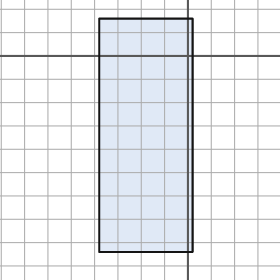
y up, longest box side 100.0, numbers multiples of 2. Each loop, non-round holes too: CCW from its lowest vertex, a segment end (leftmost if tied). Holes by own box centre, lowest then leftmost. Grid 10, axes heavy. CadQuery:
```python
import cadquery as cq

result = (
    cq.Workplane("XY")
    .moveTo(-38.0, -84.0)
    .lineTo(2.0, -84.0)
    .lineTo(2.0, 16.0)
    .lineTo(-38.0, 16.0)
    .close()
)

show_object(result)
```